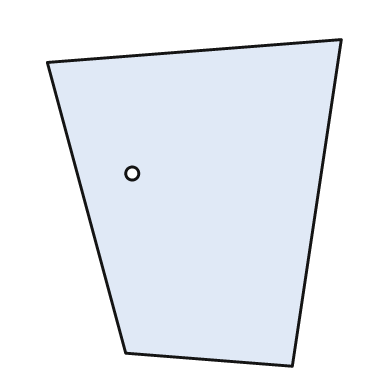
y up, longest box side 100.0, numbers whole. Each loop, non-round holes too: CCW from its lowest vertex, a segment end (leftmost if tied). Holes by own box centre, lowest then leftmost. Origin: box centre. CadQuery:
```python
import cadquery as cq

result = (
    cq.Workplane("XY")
    .moveTo(30.0, -50.0)
    .lineTo(45.0, 50.0)
    .lineTo(-45.0, 43.0)
    .lineTo(-21.0, -46.0)
    .close()
    .moveTo(-19.0, 9.0)
    .circle(2.0)
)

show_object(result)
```